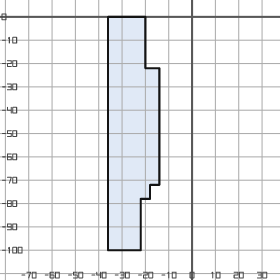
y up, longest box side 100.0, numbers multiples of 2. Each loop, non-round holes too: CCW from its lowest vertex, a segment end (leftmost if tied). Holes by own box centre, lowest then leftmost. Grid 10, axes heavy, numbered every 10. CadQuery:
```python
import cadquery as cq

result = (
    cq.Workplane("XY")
    .moveTo(-36.0, -100.0)
    .lineTo(-22.0, -100.0)
    .lineTo(-22.0, -78.0)
    .lineTo(-18.0, -78.0)
    .lineTo(-18.0, -72.0)
    .lineTo(-14.0, -72.0)
    .lineTo(-14.0, -22.0)
    .lineTo(-20.0, -22.0)
    .lineTo(-20.0, 0.0)
    .lineTo(-36.0, 0.0)
    .close()
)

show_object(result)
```